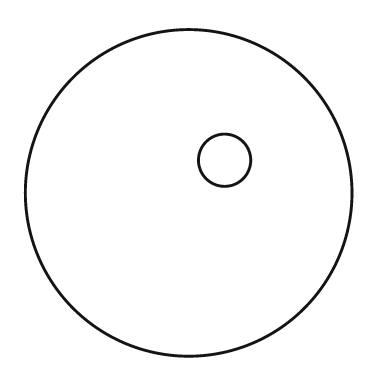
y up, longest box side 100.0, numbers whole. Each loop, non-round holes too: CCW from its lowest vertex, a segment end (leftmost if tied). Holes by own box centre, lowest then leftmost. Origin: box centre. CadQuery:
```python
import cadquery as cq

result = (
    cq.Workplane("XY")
    .moveTo(0.0, 0.0)
    .circle(50.0)
    .moveTo(11.0, 10.0)
    .circle(8.0)
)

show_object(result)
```